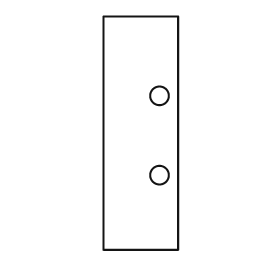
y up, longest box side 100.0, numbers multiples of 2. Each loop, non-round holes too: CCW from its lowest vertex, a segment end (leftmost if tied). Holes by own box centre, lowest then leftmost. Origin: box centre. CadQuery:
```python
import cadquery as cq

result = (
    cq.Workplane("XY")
    .moveTo(-16.0, -50.0)
    .lineTo(16.0, -50.0)
    .lineTo(16.0, 50.0)
    .lineTo(-16.0, 50.0)
    .close()
    .moveTo(8.0, -18.0)
    .circle(4.0)
    .moveTo(8.0, 16.0)
    .circle(4.0)
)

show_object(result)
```